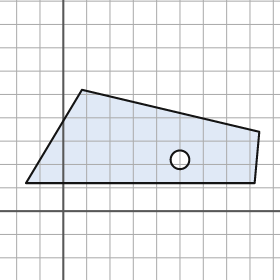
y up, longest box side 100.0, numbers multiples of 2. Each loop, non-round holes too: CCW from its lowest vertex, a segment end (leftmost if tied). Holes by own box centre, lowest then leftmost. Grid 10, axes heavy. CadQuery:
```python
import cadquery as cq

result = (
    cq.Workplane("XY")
    .moveTo(-16.0, 12.0)
    .lineTo(82.0, 12.0)
    .lineTo(84.0, 34.0)
    .lineTo(8.0, 52.0)
    .close()
    .moveTo(50.0, 22.0)
    .circle(4.0)
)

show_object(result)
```